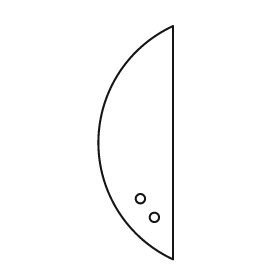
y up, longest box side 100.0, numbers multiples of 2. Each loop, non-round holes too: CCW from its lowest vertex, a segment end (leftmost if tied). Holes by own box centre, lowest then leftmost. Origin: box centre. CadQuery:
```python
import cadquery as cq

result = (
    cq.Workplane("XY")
    .moveTo(16.0, -50.0)
    .lineTo(16.0, 50.0)
    .threePointArc((-16.0, 0.0), (16.0, -50.0))
    .close()
    .moveTo(8.0, -32.0)
    .circle(2.0)
    .moveTo(2.0, -24.0)
    .circle(2.0)
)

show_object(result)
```